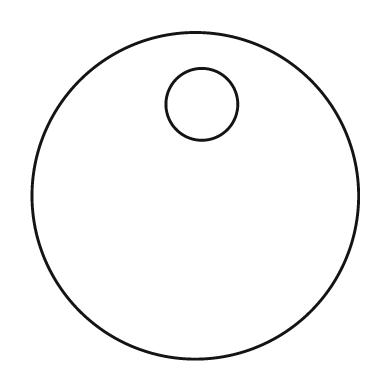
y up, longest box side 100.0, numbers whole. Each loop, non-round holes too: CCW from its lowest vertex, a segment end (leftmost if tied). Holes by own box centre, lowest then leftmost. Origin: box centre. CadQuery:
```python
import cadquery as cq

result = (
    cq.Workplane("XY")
    .moveTo(0.0, 0.0)
    .circle(50.0)
    .moveTo(2.0, 28.0)
    .circle(11.0)
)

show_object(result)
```